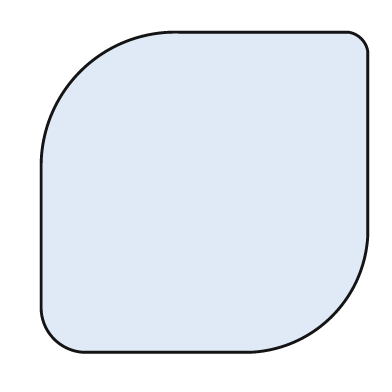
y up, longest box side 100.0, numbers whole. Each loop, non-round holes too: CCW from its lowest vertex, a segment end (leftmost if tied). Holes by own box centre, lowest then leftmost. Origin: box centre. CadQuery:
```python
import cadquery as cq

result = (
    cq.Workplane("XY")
    .moveTo(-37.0, -49.0)
    .lineTo(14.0, -49.0)
    .threePointArc((39.0, -38.0), (50.0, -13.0))
    .lineTo(50.0, 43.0)
    .threePointArc((48.0, 47.0), (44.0, 49.0))
    .lineTo(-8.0, 49.0)
    .threePointArc((-38.0, 37.0), (-50.0, 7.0))
    .lineTo(-50.0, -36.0)
    .threePointArc((-46.0, -45.0), (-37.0, -49.0))
    .close()
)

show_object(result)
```